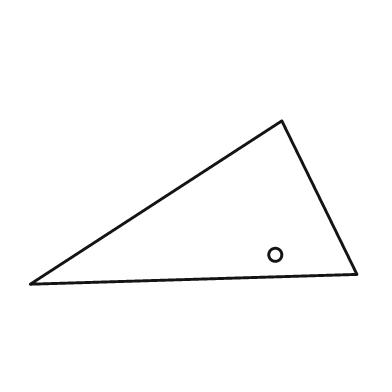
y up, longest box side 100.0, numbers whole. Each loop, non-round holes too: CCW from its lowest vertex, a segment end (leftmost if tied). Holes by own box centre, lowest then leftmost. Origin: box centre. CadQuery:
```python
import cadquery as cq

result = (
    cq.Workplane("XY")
    .moveTo(-50.0, -25.0)
    .lineTo(50.0, -22.0)
    .lineTo(27.0, 25.0)
    .close()
    .moveTo(25.0, -16.0)
    .circle(2.0)
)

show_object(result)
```